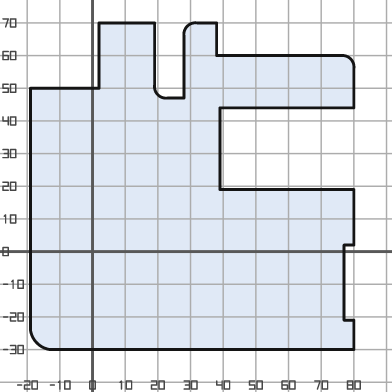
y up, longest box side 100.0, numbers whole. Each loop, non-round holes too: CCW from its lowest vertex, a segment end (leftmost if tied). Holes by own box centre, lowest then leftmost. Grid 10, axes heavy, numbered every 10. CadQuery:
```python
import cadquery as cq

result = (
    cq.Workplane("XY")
    .moveTo(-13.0, -30.0)
    .lineTo(80.0, -30.0)
    .lineTo(80.0, -21.0)
    .lineTo(77.0, -21.0)
    .lineTo(77.0, 2.0)
    .lineTo(80.0, 2.0)
    .lineTo(80.0, 19.0)
    .lineTo(39.0, 19.0)
    .lineTo(39.0, 44.0)
    .lineTo(80.0, 44.0)
    .lineTo(80.0, 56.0)
    .threePointArc((79.0, 59.0), (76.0, 60.0))
    .lineTo(38.0, 60.0)
    .lineTo(38.0, 70.0)
    .lineTo(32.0, 70.0)
    .threePointArc((29.0, 69.0), (28.0, 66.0))
    .lineTo(28.0, 47.0)
    .lineTo(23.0, 47.0)
    .threePointArc((20.0, 48.0), (19.0, 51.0))
    .lineTo(19.0, 70.0)
    .lineTo(2.0, 70.0)
    .lineTo(2.0, 50.0)
    .lineTo(-19.0, 50.0)
    .lineTo(-19.0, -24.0)
    .threePointArc((-17.0, -28.0), (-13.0, -30.0))
    .close()
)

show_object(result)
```